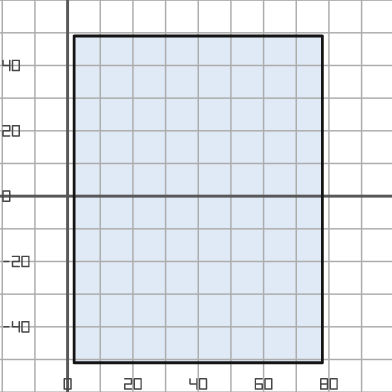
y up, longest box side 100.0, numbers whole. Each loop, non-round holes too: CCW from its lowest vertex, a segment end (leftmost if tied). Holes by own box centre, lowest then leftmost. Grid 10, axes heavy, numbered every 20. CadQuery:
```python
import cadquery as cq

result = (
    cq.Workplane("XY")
    .moveTo(2.0, -51.0)
    .lineTo(78.0, -51.0)
    .lineTo(78.0, 49.0)
    .lineTo(2.0, 49.0)
    .close()
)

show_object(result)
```